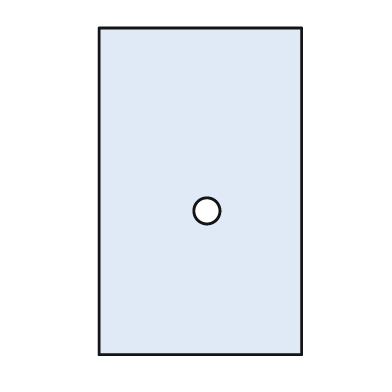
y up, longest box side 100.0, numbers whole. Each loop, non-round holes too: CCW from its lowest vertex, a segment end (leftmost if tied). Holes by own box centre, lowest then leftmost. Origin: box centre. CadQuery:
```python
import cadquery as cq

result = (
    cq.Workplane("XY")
    .moveTo(-31.0, -50.0)
    .lineTo(31.0, -50.0)
    .lineTo(31.0, 50.0)
    .lineTo(-31.0, 50.0)
    .close()
    .moveTo(2.0, -6.0)
    .circle(4.0)
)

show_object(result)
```